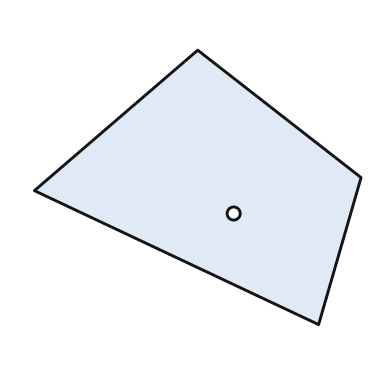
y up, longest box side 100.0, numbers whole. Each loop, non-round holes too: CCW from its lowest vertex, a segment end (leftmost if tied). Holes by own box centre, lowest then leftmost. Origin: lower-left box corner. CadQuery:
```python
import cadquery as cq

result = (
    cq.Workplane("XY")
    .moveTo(87.0, 0.0)
    .lineTo(100.0, 45.0)
    .lineTo(50.0, 84.0)
    .lineTo(0.0, 41.0)
    .close()
    .moveTo(61.0, 34.0)
    .circle(2.0)
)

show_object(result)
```